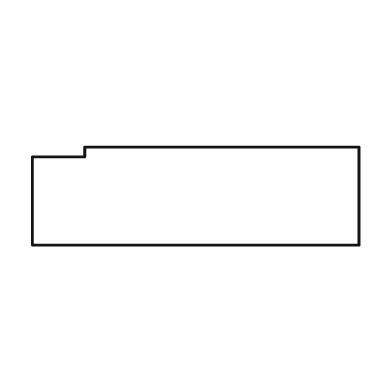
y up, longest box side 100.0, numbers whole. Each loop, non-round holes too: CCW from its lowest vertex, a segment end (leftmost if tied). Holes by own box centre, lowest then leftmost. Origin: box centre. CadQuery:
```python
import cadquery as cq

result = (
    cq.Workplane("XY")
    .moveTo(-50.0, -15.0)
    .lineTo(50.0, -15.0)
    .lineTo(50.0, 15.0)
    .lineTo(-34.0, 15.0)
    .lineTo(-34.0, 12.0)
    .lineTo(-50.0, 12.0)
    .close()
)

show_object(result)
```